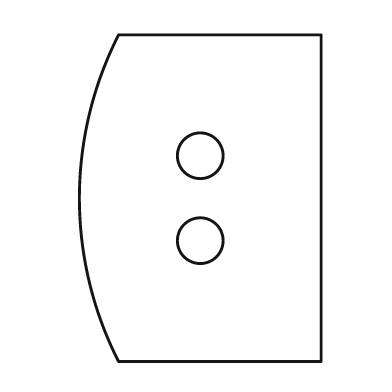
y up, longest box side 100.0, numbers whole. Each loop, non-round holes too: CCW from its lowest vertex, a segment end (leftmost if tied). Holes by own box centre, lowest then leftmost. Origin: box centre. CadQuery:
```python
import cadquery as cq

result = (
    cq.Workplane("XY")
    .moveTo(-25.0, -50.0)
    .lineTo(37.0, -50.0)
    .lineTo(37.0, 50.0)
    .lineTo(-25.0, 50.0)
    .threePointArc((-37.0, 0.0), (-25.0, -50.0))
    .close()
    .moveTo(0.0, -13.0)
    .circle(7.0)
    .moveTo(0.0, 13.0)
    .circle(7.0)
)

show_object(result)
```